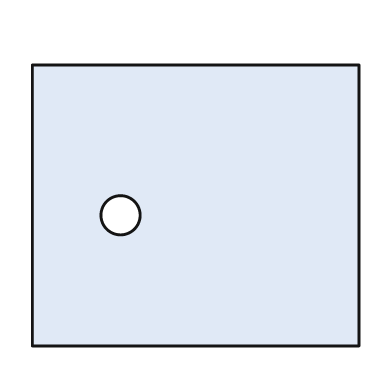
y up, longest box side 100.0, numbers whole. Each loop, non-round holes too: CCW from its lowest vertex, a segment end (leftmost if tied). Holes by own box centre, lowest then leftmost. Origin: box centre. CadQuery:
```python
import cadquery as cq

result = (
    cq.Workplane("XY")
    .moveTo(-50.0, -43.0)
    .lineTo(50.0, -43.0)
    .lineTo(50.0, 43.0)
    .lineTo(-50.0, 43.0)
    .close()
    .moveTo(-23.0, -3.0)
    .circle(6.0)
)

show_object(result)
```